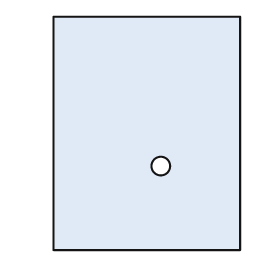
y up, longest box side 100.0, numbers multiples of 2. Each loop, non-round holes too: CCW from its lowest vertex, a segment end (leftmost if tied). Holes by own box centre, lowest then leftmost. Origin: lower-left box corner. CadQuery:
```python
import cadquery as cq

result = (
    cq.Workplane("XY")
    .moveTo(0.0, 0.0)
    .lineTo(80.0, 0.0)
    .lineTo(80.0, 100.0)
    .lineTo(0.0, 100.0)
    .close()
    .moveTo(46.0, 36.0)
    .circle(4.0)
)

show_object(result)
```